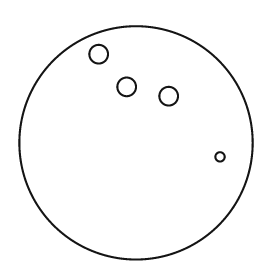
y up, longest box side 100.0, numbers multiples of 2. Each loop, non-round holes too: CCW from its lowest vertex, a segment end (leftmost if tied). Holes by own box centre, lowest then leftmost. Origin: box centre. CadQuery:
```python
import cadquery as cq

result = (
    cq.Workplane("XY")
    .moveTo(0.0, 0.0)
    .circle(50.0)
    .moveTo(36.0, -6.0)
    .circle(2.0)
    .moveTo(14.0, 20.0)
    .circle(4.0)
    .moveTo(-4.0, 24.0)
    .circle(4.0)
    .moveTo(-16.0, 38.0)
    .circle(4.0)
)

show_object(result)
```